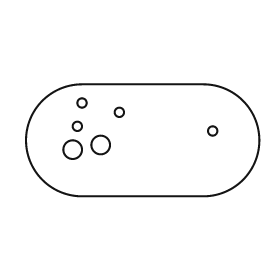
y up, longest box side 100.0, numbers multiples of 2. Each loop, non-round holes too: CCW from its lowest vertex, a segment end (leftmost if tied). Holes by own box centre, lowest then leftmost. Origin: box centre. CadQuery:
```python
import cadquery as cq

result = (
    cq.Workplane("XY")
    .moveTo(-26.0, -24.0)
    .lineTo(26.0, -24.0)
    .threePointArc((50.0, 0.0), (26.0, 24.0))
    .lineTo(-26.0, 24.0)
    .threePointArc((-50.0, 0.0), (-26.0, -24.0))
    .close()
    .moveTo(-30.0, -4.0)
    .circle(4.0)
    .moveTo(-18.0, -2.0)
    .circle(4.0)
    .moveTo(30.0, 4.0)
    .circle(2.0)
    .moveTo(-28.0, 6.0)
    .circle(2.0)
    .moveTo(-10.0, 12.0)
    .circle(2.0)
    .moveTo(-26.0, 16.0)
    .circle(2.0)
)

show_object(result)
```